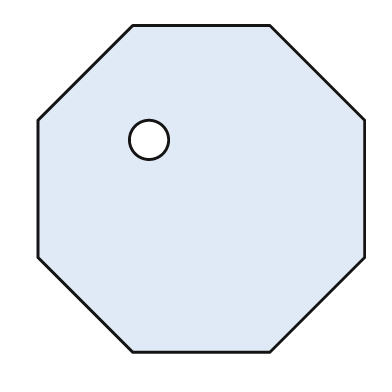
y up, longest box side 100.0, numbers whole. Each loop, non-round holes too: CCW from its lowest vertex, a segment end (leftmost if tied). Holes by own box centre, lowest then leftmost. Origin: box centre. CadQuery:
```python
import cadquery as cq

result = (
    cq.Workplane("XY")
    .moveTo(-21.0, -50.0)
    .lineTo(21.0, -50.0)
    .lineTo(50.0, -21.0)
    .lineTo(50.0, 21.0)
    .lineTo(21.0, 50.0)
    .lineTo(-21.0, 50.0)
    .lineTo(-50.0, 21.0)
    .lineTo(-50.0, -21.0)
    .close()
    .moveTo(-16.0, 15.0)
    .circle(6.0)
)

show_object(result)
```